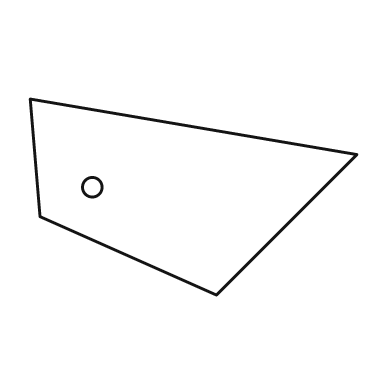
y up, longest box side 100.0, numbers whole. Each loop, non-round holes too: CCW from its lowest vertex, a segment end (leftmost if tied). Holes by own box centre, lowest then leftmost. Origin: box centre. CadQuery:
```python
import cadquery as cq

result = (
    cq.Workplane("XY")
    .moveTo(7.0, -30.0)
    .lineTo(50.0, 13.0)
    .lineTo(-50.0, 30.0)
    .lineTo(-47.0, -6.0)
    .close()
    .moveTo(-31.0, 3.0)
    .circle(3.0)
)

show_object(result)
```